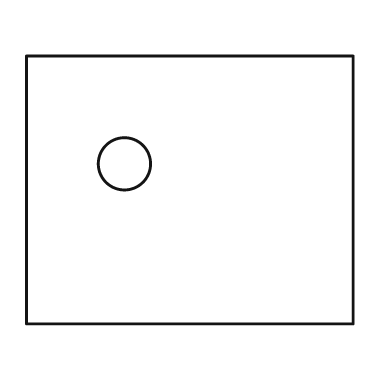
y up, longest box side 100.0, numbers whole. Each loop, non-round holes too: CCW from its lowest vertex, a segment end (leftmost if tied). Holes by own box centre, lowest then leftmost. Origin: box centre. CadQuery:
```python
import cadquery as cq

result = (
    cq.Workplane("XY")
    .moveTo(-50.0, -41.0)
    .lineTo(50.0, -41.0)
    .lineTo(50.0, 41.0)
    .lineTo(-50.0, 41.0)
    .close()
    .moveTo(-20.0, 8.0)
    .circle(8.0)
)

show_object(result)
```